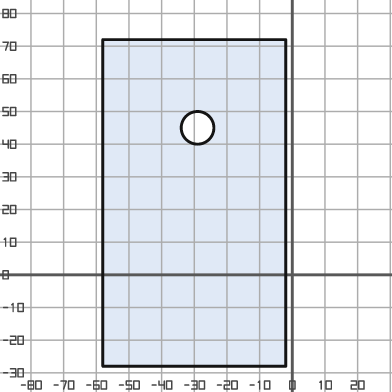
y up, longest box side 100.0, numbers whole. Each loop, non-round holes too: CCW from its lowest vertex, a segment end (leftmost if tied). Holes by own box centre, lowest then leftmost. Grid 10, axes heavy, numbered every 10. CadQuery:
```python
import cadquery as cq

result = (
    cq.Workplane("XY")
    .moveTo(-58.0, -28.0)
    .lineTo(-2.0, -28.0)
    .lineTo(-2.0, 72.0)
    .lineTo(-58.0, 72.0)
    .close()
    .moveTo(-29.0, 45.0)
    .circle(5.0)
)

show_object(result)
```